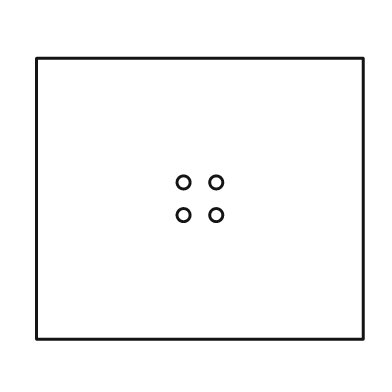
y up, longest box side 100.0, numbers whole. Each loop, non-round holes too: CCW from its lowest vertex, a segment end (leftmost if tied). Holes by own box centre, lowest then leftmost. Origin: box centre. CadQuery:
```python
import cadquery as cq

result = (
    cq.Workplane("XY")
    .moveTo(-50.0, -43.0)
    .lineTo(50.0, -43.0)
    .lineTo(50.0, 43.0)
    .lineTo(-50.0, 43.0)
    .close()
    .moveTo(-5.0, -5.0)
    .circle(2.0)
    .moveTo(5.0, -5.0)
    .circle(2.0)
    .moveTo(-5.0, 5.0)
    .circle(2.0)
    .moveTo(5.0, 5.0)
    .circle(2.0)
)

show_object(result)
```